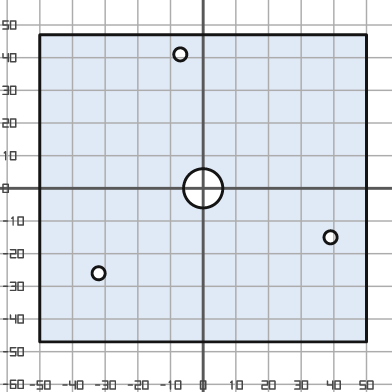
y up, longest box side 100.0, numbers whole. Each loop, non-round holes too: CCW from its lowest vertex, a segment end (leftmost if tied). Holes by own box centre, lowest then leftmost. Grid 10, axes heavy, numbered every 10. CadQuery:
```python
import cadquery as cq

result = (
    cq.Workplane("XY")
    .moveTo(-50.0, -47.0)
    .lineTo(50.0, -47.0)
    .lineTo(50.0, 47.0)
    .lineTo(-50.0, 47.0)
    .close()
    .moveTo(-32.0, -26.0)
    .circle(2.0)
    .moveTo(39.0, -15.0)
    .circle(2.0)
    .moveTo(0.0, 0.0)
    .circle(6.0)
    .moveTo(-7.0, 41.0)
    .circle(2.0)
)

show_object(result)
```